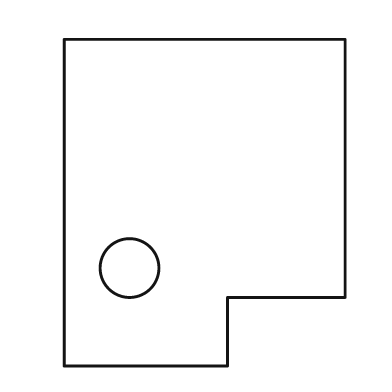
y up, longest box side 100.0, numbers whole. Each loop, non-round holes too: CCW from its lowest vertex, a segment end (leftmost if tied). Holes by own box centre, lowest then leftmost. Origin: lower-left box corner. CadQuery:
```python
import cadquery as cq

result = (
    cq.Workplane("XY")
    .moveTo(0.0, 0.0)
    .lineTo(50.0, 0.0)
    .lineTo(50.0, 21.0)
    .lineTo(86.0, 21.0)
    .lineTo(86.0, 100.0)
    .lineTo(0.0, 100.0)
    .close()
    .moveTo(20.0, 30.0)
    .circle(9.0)
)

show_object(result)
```